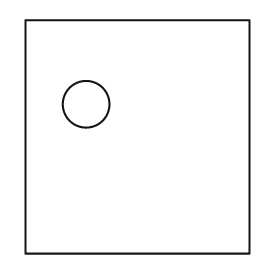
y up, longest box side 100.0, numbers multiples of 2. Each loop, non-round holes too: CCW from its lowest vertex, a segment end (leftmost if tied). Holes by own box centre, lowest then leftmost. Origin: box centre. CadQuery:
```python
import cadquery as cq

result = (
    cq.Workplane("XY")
    .moveTo(-48.0, -50.0)
    .lineTo(48.0, -50.0)
    .lineTo(48.0, 50.0)
    .lineTo(-48.0, 50.0)
    .close()
    .moveTo(-22.0, 14.0)
    .circle(10.0)
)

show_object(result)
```